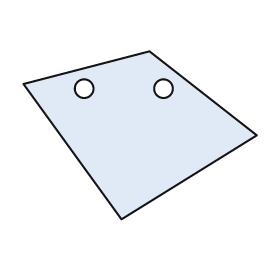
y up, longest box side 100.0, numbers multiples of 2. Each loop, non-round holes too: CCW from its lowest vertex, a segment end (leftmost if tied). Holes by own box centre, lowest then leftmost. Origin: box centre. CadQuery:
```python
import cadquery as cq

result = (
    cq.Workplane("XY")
    .moveTo(-8.0, -36.0)
    .lineTo(50.0, 0.0)
    .lineTo(4.0, 36.0)
    .lineTo(-50.0, 22.0)
    .close()
    .moveTo(-24.0, 20.0)
    .circle(4.0)
    .moveTo(10.0, 20.0)
    .circle(4.0)
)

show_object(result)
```